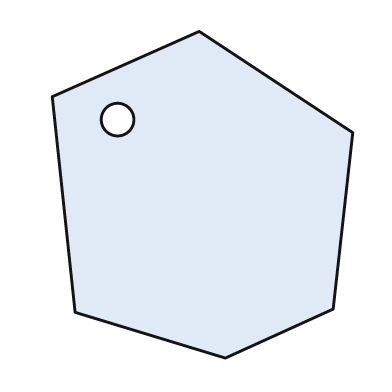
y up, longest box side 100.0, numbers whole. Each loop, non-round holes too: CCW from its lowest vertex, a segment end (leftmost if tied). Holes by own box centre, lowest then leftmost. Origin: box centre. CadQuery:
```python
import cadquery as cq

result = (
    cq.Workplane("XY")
    .moveTo(7.0, -50.0)
    .lineTo(40.0, -35.0)
    .lineTo(46.0, 19.0)
    .lineTo(-1.0, 50.0)
    .lineTo(-46.0, 30.0)
    .lineTo(-39.0, -36.0)
    .close()
    .moveTo(-26.0, 23.0)
    .circle(5.0)
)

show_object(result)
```